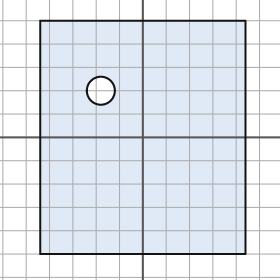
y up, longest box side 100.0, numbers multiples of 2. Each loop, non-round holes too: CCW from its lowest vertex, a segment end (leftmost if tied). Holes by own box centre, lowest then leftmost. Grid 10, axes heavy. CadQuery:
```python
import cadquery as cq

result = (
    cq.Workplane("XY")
    .moveTo(-44.0, -50.0)
    .lineTo(44.0, -50.0)
    .lineTo(44.0, 50.0)
    .lineTo(-44.0, 50.0)
    .close()
    .moveTo(-18.0, 20.0)
    .circle(6.0)
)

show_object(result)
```